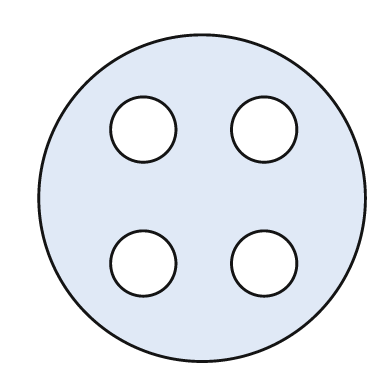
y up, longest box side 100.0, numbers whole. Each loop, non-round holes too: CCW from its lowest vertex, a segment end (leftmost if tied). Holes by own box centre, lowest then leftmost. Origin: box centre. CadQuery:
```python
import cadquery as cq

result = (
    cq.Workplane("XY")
    .moveTo(0.0, 0.0)
    .circle(50.0)
    .moveTo(-18.0, -20.0)
    .circle(10.0)
    .moveTo(19.0, -20.0)
    .circle(10.0)
    .moveTo(-18.0, 21.0)
    .circle(10.0)
    .moveTo(19.0, 21.0)
    .circle(10.0)
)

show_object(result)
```